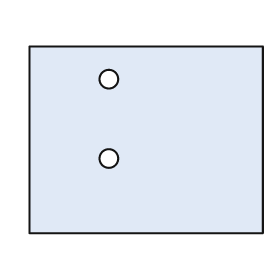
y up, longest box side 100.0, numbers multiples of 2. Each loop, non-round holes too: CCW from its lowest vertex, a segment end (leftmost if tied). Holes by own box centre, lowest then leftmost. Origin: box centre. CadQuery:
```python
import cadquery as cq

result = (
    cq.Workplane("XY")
    .moveTo(-50.0, -40.0)
    .lineTo(50.0, -40.0)
    .lineTo(50.0, 40.0)
    .lineTo(-50.0, 40.0)
    .close()
    .moveTo(-16.0, -8.0)
    .circle(4.0)
    .moveTo(-16.0, 26.0)
    .circle(4.0)
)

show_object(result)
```